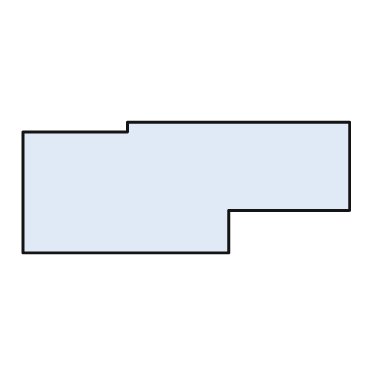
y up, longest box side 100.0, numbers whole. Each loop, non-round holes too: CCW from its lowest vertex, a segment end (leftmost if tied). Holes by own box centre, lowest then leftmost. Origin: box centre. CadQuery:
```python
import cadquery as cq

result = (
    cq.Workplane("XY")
    .moveTo(-50.0, -20.0)
    .lineTo(13.0, -20.0)
    .lineTo(13.0, -7.0)
    .lineTo(50.0, -7.0)
    .lineTo(50.0, 20.0)
    .lineTo(-18.0, 20.0)
    .lineTo(-18.0, 17.0)
    .lineTo(-50.0, 17.0)
    .close()
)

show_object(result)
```